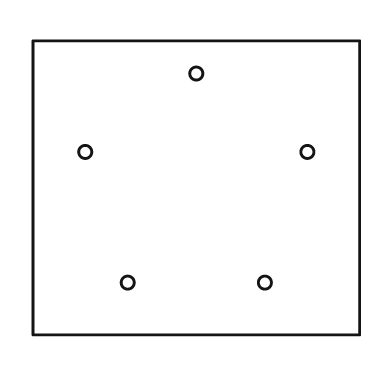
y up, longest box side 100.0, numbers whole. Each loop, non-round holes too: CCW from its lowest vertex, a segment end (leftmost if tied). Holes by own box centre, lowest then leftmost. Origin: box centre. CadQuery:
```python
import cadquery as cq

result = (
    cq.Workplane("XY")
    .moveTo(-50.0, -45.0)
    .lineTo(50.0, -45.0)
    .lineTo(50.0, 45.0)
    .lineTo(-50.0, 45.0)
    .close()
    .moveTo(-21.0, -29.0)
    .circle(2.0)
    .moveTo(21.0, -29.0)
    .circle(2.0)
    .moveTo(-34.0, 11.0)
    .circle(2.0)
    .moveTo(34.0, 11.0)
    .circle(2.0)
    .moveTo(0.0, 35.0)
    .circle(2.0)
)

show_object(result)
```